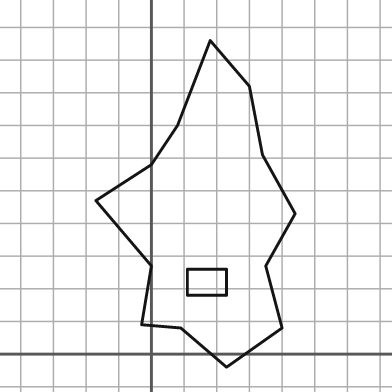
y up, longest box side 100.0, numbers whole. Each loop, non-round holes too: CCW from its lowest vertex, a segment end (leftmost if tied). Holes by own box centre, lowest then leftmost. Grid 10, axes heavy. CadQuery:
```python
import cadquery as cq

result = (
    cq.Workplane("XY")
    .moveTo(23.0, -4.0)
    .lineTo(40.0, 8.0)
    .lineTo(35.0, 27.0)
    .lineTo(44.0, 43.0)
    .lineTo(34.0, 61.0)
    .lineTo(30.0, 82.0)
    .lineTo(18.0, 96.0)
    .lineTo(8.0, 70.0)
    .lineTo(0.0, 58.0)
    .lineTo(-17.0, 47.0)
    .lineTo(0.0, 27.0)
    .lineTo(-3.0, 9.0)
    .lineTo(9.0, 8.0)
    .close()
    .moveTo(11.0, 18.0)
    .lineTo(23.0, 18.0)
    .lineTo(23.0, 26.0)
    .lineTo(11.0, 26.0)
    .close()
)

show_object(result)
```